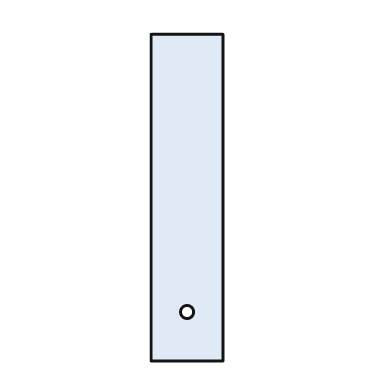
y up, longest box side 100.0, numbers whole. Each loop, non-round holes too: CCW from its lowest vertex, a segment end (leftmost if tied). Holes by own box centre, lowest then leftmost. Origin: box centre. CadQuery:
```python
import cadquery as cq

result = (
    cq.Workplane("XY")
    .moveTo(-11.0, -50.0)
    .lineTo(11.0, -50.0)
    .lineTo(11.0, 50.0)
    .lineTo(-11.0, 50.0)
    .close()
    .moveTo(0.0, -35.0)
    .circle(2.0)
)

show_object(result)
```